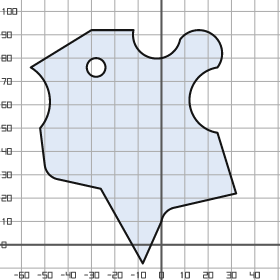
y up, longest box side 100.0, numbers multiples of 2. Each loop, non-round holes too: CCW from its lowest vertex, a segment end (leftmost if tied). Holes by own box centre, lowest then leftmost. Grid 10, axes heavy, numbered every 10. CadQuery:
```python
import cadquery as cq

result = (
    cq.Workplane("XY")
    .moveTo(-8.0, -8.0)
    .lineTo(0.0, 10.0)
    .threePointArc((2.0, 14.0), (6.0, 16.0))
    .lineTo(32.0, 22.0)
    .lineTo(24.0, 48.0)
    .threePointArc((12.0, 62.0), (24.0, 76.0))
    .threePointArc((22.0, 90.0), (8.0, 88.0))
    .threePointArc((-4.0, 80.0), (-12.0, 92.0))
    .lineTo(-30.0, 92.0)
    .lineTo(-56.0, 76.0)
    .threePointArc((-48.0, 64.0), (-52.0, 50.0))
    .lineTo(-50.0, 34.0)
    .threePointArc((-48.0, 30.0), (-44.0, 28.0))
    .lineTo(-26.0, 24.0)
    .close()
    .moveTo(-28.0, 76.0)
    .circle(4.0)
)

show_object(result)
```